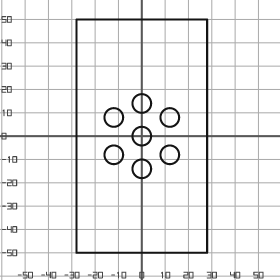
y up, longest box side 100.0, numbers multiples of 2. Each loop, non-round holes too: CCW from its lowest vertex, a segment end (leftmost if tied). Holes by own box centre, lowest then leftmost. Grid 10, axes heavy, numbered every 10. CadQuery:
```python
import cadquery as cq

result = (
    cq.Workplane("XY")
    .moveTo(-28.0, -50.0)
    .lineTo(28.0, -50.0)
    .lineTo(28.0, 50.0)
    .lineTo(-28.0, 50.0)
    .close()
    .moveTo(0.0, -14.0)
    .circle(4.0)
    .moveTo(-12.0, -8.0)
    .circle(4.0)
    .moveTo(12.0, -8.0)
    .circle(4.0)
    .moveTo(0.0, 0.0)
    .circle(4.0)
    .moveTo(-12.0, 8.0)
    .circle(4.0)
    .moveTo(12.0, 8.0)
    .circle(4.0)
    .moveTo(0.0, 14.0)
    .circle(4.0)
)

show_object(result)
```